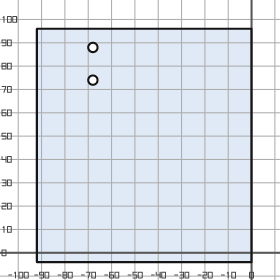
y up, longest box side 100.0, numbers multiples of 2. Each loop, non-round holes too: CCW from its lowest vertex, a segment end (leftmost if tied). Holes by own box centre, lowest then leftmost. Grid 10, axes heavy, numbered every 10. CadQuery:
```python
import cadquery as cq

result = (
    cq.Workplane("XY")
    .moveTo(-92.0, -4.0)
    .lineTo(0.0, -4.0)
    .lineTo(0.0, 96.0)
    .lineTo(-92.0, 96.0)
    .close()
    .moveTo(-68.0, 74.0)
    .circle(2.0)
    .moveTo(-68.0, 88.0)
    .circle(2.0)
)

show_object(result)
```